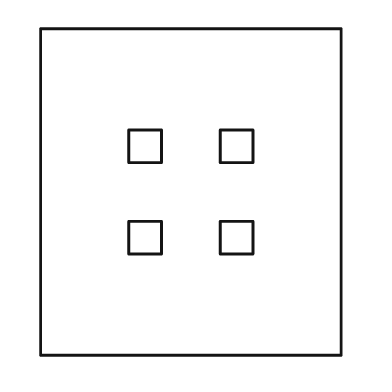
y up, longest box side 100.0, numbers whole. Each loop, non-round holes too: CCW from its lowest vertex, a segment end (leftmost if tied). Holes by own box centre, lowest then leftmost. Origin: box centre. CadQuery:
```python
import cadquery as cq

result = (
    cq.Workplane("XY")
    .moveTo(-46.0, -50.0)
    .lineTo(46.0, -50.0)
    .lineTo(46.0, 50.0)
    .lineTo(-46.0, 50.0)
    .close()
    .moveTo(-19.0, -19.0)
    .lineTo(-9.0, -19.0)
    .lineTo(-9.0, -9.0)
    .lineTo(-19.0, -9.0)
    .close()
    .moveTo(9.0, -19.0)
    .lineTo(19.0, -19.0)
    .lineTo(19.0, -9.0)
    .lineTo(9.0, -9.0)
    .close()
    .moveTo(-19.0, 9.0)
    .lineTo(-9.0, 9.0)
    .lineTo(-9.0, 19.0)
    .lineTo(-19.0, 19.0)
    .close()
    .moveTo(9.0, 9.0)
    .lineTo(19.0, 9.0)
    .lineTo(19.0, 19.0)
    .lineTo(9.0, 19.0)
    .close()
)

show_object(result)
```